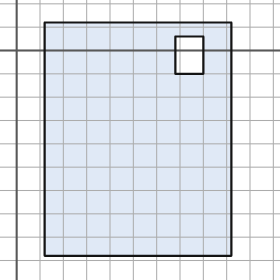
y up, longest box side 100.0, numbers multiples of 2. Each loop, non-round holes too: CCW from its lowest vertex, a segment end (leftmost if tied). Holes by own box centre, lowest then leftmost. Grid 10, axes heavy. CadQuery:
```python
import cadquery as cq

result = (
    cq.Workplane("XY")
    .moveTo(12.0, -88.0)
    .lineTo(92.0, -88.0)
    .lineTo(92.0, 12.0)
    .lineTo(12.0, 12.0)
    .close()
    .moveTo(68.0, -10.0)
    .lineTo(80.0, -10.0)
    .lineTo(80.0, 6.0)
    .lineTo(68.0, 6.0)
    .close()
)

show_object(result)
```